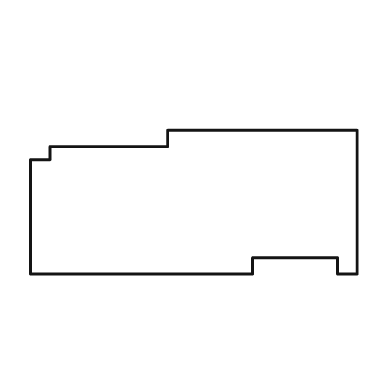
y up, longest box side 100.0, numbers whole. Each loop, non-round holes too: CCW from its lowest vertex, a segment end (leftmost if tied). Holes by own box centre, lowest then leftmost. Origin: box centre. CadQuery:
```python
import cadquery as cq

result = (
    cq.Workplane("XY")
    .moveTo(-50.0, -22.0)
    .lineTo(18.0, -22.0)
    .lineTo(18.0, -17.0)
    .lineTo(44.0, -17.0)
    .lineTo(44.0, -22.0)
    .lineTo(50.0, -22.0)
    .lineTo(50.0, 22.0)
    .lineTo(-8.0, 22.0)
    .lineTo(-8.0, 17.0)
    .lineTo(-44.0, 17.0)
    .lineTo(-44.0, 13.0)
    .lineTo(-50.0, 13.0)
    .close()
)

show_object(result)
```